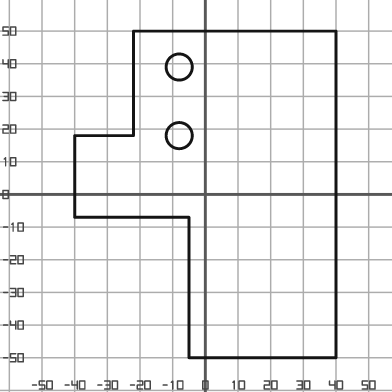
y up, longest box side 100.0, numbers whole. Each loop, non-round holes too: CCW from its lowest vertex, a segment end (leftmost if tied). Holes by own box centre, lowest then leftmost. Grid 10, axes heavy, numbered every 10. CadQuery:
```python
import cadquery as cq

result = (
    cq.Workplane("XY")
    .moveTo(-5.0, -50.0)
    .lineTo(40.0, -50.0)
    .lineTo(40.0, 50.0)
    .lineTo(-22.0, 50.0)
    .lineTo(-22.0, 18.0)
    .lineTo(-40.0, 18.0)
    .lineTo(-40.0, -7.0)
    .lineTo(-5.0, -7.0)
    .close()
    .moveTo(-8.0, 18.0)
    .circle(4.0)
    .moveTo(-8.0, 39.0)
    .circle(4.0)
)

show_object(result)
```